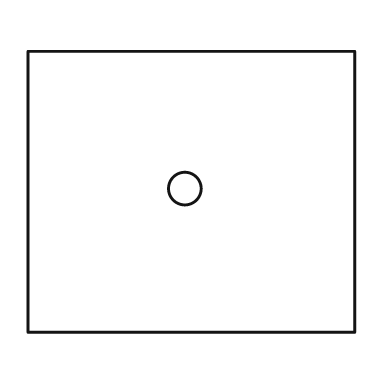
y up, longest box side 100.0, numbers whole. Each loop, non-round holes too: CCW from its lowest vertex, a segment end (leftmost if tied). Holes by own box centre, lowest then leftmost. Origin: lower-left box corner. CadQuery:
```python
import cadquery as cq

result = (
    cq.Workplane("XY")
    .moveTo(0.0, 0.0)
    .lineTo(100.0, 0.0)
    .lineTo(100.0, 86.0)
    .lineTo(0.0, 86.0)
    .close()
    .moveTo(48.0, 44.0)
    .circle(5.0)
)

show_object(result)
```